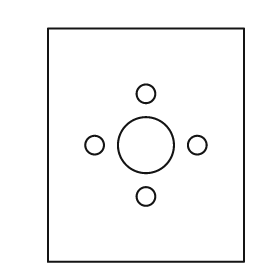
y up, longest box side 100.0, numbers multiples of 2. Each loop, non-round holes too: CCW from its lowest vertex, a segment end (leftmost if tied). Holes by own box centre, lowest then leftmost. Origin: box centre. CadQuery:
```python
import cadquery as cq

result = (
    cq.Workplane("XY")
    .moveTo(-42.0, -50.0)
    .lineTo(42.0, -50.0)
    .lineTo(42.0, 50.0)
    .lineTo(-42.0, 50.0)
    .close()
    .moveTo(0.0, -22.0)
    .circle(4.0)
    .moveTo(-22.0, 0.0)
    .circle(4.0)
    .moveTo(0.0, 0.0)
    .circle(12.0)
    .moveTo(22.0, 0.0)
    .circle(4.0)
    .moveTo(0.0, 22.0)
    .circle(4.0)
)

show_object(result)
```